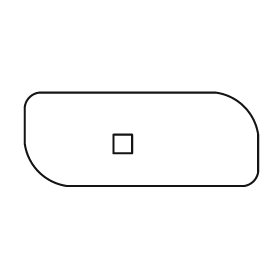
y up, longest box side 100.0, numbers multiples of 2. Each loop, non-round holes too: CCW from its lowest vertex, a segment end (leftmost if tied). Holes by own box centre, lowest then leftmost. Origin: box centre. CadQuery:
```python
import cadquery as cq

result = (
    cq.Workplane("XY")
    .moveTo(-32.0, -20.0)
    .lineTo(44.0, -20.0)
    .threePointArc((48.0, -18.0), (50.0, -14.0))
    .lineTo(50.0, 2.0)
    .threePointArc((44.0, 14.0), (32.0, 20.0))
    .lineTo(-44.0, 20.0)
    .threePointArc((-48.0, 18.0), (-50.0, 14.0))
    .lineTo(-50.0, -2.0)
    .threePointArc((-44.0, -14.0), (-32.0, -20.0))
    .close()
    .moveTo(-12.0, -6.0)
    .lineTo(-4.0, -6.0)
    .lineTo(-4.0, 2.0)
    .lineTo(-12.0, 2.0)
    .close()
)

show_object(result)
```